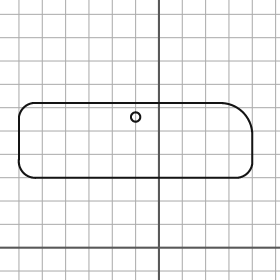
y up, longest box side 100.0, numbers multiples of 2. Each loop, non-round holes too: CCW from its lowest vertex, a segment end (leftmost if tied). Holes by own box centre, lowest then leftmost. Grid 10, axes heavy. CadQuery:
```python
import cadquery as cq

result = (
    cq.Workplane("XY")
    .moveTo(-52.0, 30.0)
    .lineTo(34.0, 30.0)
    .threePointArc((38.0, 32.0), (40.0, 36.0))
    .lineTo(40.0, 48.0)
    .threePointArc((36.0, 58.0), (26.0, 62.0))
    .lineTo(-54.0, 62.0)
    .threePointArc((-58.0, 60.0), (-60.0, 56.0))
    .lineTo(-60.0, 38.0)
    .threePointArc((-58.0, 32.0), (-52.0, 30.0))
    .close()
    .moveTo(-10.0, 56.0)
    .circle(2.0)
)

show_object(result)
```